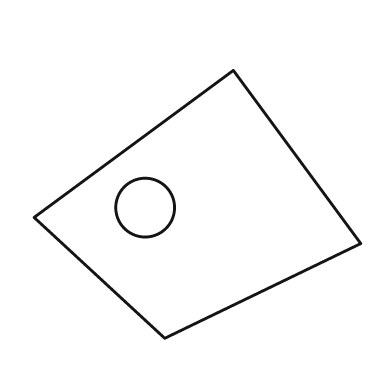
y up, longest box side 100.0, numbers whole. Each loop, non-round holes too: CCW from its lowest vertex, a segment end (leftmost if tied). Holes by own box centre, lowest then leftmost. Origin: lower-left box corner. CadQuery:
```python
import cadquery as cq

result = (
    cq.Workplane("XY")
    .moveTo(40.0, 0.0)
    .lineTo(100.0, 29.0)
    .lineTo(61.0, 82.0)
    .lineTo(0.0, 37.0)
    .close()
    .moveTo(34.0, 40.0)
    .circle(9.0)
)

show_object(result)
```